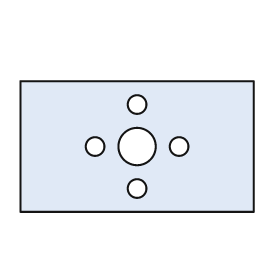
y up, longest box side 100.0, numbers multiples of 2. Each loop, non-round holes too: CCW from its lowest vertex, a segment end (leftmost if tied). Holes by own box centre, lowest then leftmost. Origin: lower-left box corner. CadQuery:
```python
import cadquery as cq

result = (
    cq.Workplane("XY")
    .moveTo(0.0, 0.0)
    .lineTo(100.0, 0.0)
    .lineTo(100.0, 56.0)
    .lineTo(0.0, 56.0)
    .close()
    .moveTo(50.0, 10.0)
    .circle(4.0)
    .moveTo(32.0, 28.0)
    .circle(4.0)
    .moveTo(50.0, 28.0)
    .circle(8.0)
    .moveTo(68.0, 28.0)
    .circle(4.0)
    .moveTo(50.0, 46.0)
    .circle(4.0)
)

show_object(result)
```